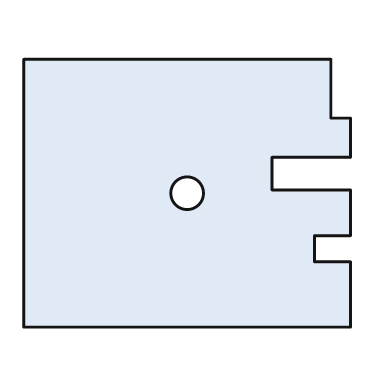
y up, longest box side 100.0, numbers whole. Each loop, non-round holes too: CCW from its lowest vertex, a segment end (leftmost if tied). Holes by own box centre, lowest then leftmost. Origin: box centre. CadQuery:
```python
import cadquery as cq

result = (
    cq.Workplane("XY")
    .moveTo(-50.0, -41.0)
    .lineTo(50.0, -41.0)
    .lineTo(50.0, -21.0)
    .lineTo(39.0, -21.0)
    .lineTo(39.0, -13.0)
    .lineTo(50.0, -13.0)
    .lineTo(50.0, 1.0)
    .lineTo(26.0, 1.0)
    .lineTo(26.0, 11.0)
    .lineTo(50.0, 11.0)
    .lineTo(50.0, 23.0)
    .lineTo(44.0, 23.0)
    .lineTo(44.0, 41.0)
    .lineTo(-50.0, 41.0)
    .close()
    .moveTo(0.0, 0.0)
    .circle(5.0)
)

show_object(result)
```